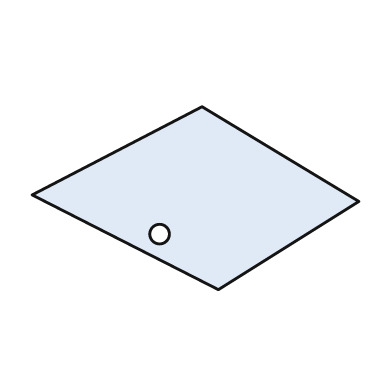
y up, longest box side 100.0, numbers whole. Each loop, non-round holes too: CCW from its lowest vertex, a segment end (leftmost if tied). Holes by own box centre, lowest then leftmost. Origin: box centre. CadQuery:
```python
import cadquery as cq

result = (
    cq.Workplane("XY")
    .moveTo(7.0, -28.0)
    .lineTo(50.0, -1.0)
    .lineTo(2.0, 28.0)
    .lineTo(-50.0, 1.0)
    .close()
    .moveTo(-11.0, -11.0)
    .circle(3.0)
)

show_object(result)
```